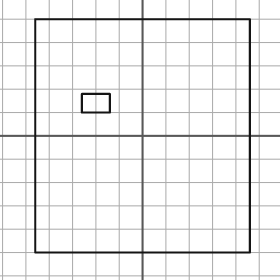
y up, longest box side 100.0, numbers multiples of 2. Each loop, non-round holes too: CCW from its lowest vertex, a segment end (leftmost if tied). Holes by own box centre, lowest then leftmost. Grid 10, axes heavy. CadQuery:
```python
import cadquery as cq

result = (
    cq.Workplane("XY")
    .moveTo(-46.0, -50.0)
    .lineTo(46.0, -50.0)
    .lineTo(46.0, 50.0)
    .lineTo(-46.0, 50.0)
    .close()
    .moveTo(-26.0, 10.0)
    .lineTo(-14.0, 10.0)
    .lineTo(-14.0, 18.0)
    .lineTo(-26.0, 18.0)
    .close()
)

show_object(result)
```